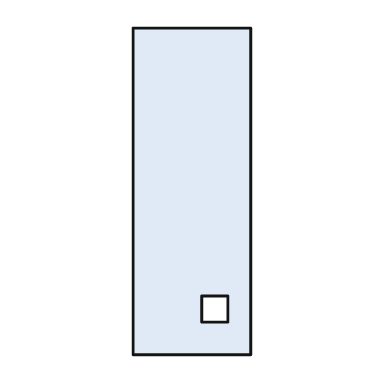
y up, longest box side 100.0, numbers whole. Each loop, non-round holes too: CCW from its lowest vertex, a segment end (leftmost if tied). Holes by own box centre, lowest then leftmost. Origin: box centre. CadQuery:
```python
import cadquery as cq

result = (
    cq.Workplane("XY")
    .moveTo(-18.0, -50.0)
    .lineTo(18.0, -50.0)
    .lineTo(18.0, 50.0)
    .lineTo(-18.0, 50.0)
    .close()
    .moveTo(3.0, -40.0)
    .lineTo(11.0, -40.0)
    .lineTo(11.0, -32.0)
    .lineTo(3.0, -32.0)
    .close()
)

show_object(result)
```